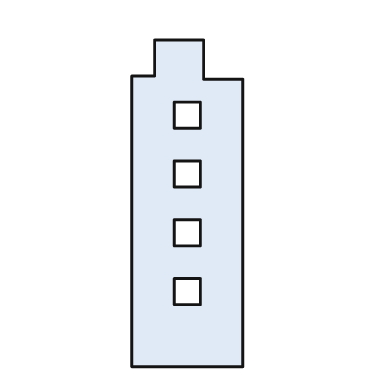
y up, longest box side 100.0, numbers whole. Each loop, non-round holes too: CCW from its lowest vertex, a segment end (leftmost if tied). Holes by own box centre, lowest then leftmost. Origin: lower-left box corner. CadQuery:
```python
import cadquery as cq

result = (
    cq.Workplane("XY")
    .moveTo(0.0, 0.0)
    .lineTo(34.0, 0.0)
    .lineTo(34.0, 88.0)
    .lineTo(22.0, 88.0)
    .lineTo(22.0, 100.0)
    .lineTo(7.0, 100.0)
    .lineTo(7.0, 89.0)
    .lineTo(0.0, 89.0)
    .close()
    .moveTo(13.0, 19.0)
    .lineTo(21.0, 19.0)
    .lineTo(21.0, 27.0)
    .lineTo(13.0, 27.0)
    .close()
    .moveTo(13.0, 37.0)
    .lineTo(21.0, 37.0)
    .lineTo(21.0, 45.0)
    .lineTo(13.0, 45.0)
    .close()
    .moveTo(13.0, 55.0)
    .lineTo(21.0, 55.0)
    .lineTo(21.0, 63.0)
    .lineTo(13.0, 63.0)
    .close()
    .moveTo(13.0, 73.0)
    .lineTo(21.0, 73.0)
    .lineTo(21.0, 81.0)
    .lineTo(13.0, 81.0)
    .close()
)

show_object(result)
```